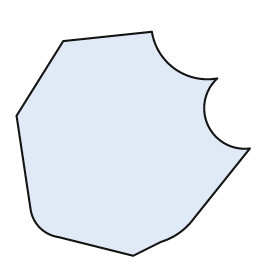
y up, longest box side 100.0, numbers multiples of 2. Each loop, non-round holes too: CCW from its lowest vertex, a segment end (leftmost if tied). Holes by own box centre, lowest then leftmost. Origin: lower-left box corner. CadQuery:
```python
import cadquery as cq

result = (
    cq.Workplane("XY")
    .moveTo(50.0, 0.0)
    .lineTo(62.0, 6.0)
    .threePointArc((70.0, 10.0), (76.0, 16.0))
    .lineTo(100.0, 46.0)
    .threePointArc((82.0, 56.0), (86.0, 76.0))
    .threePointArc((68.0, 80.0), (58.0, 96.0))
    .lineTo(20.0, 92.0)
    .lineTo(0.0, 60.0)
    .lineTo(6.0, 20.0)
    .threePointArc((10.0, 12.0), (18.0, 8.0))
    .close()
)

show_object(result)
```